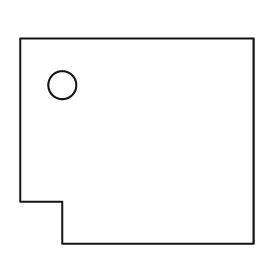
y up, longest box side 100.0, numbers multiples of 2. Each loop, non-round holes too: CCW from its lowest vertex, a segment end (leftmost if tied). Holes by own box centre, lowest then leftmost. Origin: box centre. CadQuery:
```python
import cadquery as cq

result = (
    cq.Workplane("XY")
    .moveTo(-32.0, -44.0)
    .lineTo(50.0, -44.0)
    .lineTo(50.0, 44.0)
    .lineTo(-50.0, 44.0)
    .lineTo(-50.0, -26.0)
    .lineTo(-32.0, -26.0)
    .close()
    .moveTo(-32.0, 24.0)
    .circle(6.0)
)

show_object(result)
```